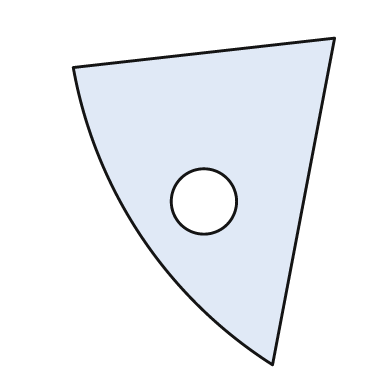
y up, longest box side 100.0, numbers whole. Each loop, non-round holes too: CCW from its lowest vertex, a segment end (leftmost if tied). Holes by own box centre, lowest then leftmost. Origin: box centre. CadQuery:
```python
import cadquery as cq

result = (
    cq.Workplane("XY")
    .moveTo(21.0, -50.0)
    .lineTo(40.0, 50.0)
    .lineTo(-40.0, 41.0)
    .threePointArc((-19.0, -11.0), (21.0, -50.0))
    .close()
    .moveTo(0.0, 0.0)
    .circle(10.0)
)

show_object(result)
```